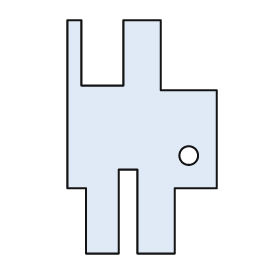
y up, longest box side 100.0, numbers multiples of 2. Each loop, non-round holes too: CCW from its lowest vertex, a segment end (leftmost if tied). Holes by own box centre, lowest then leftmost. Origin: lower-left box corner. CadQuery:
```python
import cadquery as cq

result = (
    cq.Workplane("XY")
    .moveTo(8.0, 0.0)
    .lineTo(22.0, 0.0)
    .lineTo(22.0, 36.0)
    .lineTo(30.0, 36.0)
    .lineTo(30.0, 0.0)
    .lineTo(46.0, 0.0)
    .lineTo(46.0, 28.0)
    .lineTo(64.0, 28.0)
    .lineTo(64.0, 70.0)
    .lineTo(40.0, 70.0)
    .lineTo(40.0, 100.0)
    .lineTo(24.0, 100.0)
    .lineTo(24.0, 72.0)
    .lineTo(6.0, 72.0)
    .lineTo(6.0, 100.0)
    .lineTo(0.0, 100.0)
    .lineTo(0.0, 28.0)
    .lineTo(8.0, 28.0)
    .close()
    .moveTo(52.0, 42.0)
    .circle(4.0)
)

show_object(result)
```